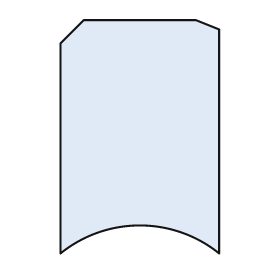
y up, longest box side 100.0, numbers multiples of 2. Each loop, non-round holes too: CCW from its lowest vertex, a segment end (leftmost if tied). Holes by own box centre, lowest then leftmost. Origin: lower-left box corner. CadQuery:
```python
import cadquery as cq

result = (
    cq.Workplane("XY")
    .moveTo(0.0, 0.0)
    .threePointArc((34.0, 12.0), (68.0, 0.0))
    .lineTo(68.0, 96.0)
    .lineTo(58.0, 100.0)
    .lineTo(10.0, 100.0)
    .lineTo(0.0, 90.0)
    .close()
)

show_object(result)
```